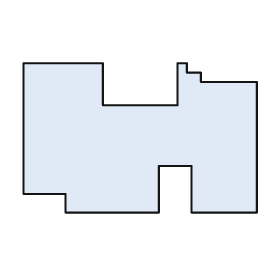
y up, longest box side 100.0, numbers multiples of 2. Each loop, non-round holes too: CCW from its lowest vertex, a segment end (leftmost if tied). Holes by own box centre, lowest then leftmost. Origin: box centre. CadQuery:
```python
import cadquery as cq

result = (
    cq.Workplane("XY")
    .moveTo(-32.0, -32.0)
    .lineTo(8.0, -32.0)
    .lineTo(8.0, -12.0)
    .lineTo(22.0, -12.0)
    .lineTo(22.0, -32.0)
    .lineTo(50.0, -32.0)
    .lineTo(50.0, 24.0)
    .lineTo(26.0, 24.0)
    .lineTo(26.0, 28.0)
    .lineTo(20.0, 28.0)
    .lineTo(20.0, 32.0)
    .lineTo(16.0, 32.0)
    .lineTo(16.0, 14.0)
    .lineTo(-16.0, 14.0)
    .lineTo(-16.0, 32.0)
    .lineTo(-50.0, 32.0)
    .lineTo(-50.0, -24.0)
    .lineTo(-32.0, -24.0)
    .close()
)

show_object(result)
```